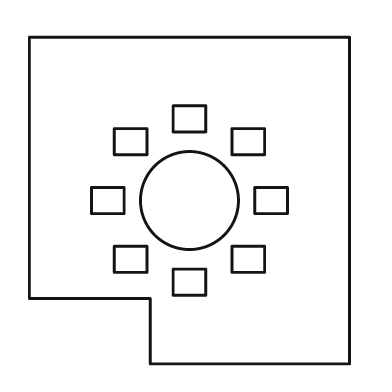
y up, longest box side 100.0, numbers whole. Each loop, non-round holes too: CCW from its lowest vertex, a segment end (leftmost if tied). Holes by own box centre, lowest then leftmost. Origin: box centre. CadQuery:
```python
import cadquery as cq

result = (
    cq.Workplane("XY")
    .moveTo(-12.0, -50.0)
    .lineTo(49.0, -50.0)
    .lineTo(49.0, 50.0)
    .lineTo(-49.0, 50.0)
    .lineTo(-49.0, -30.0)
    .lineTo(-12.0, -30.0)
    .close()
    .moveTo(-5.0, -29.0)
    .lineTo(5.0, -29.0)
    .lineTo(5.0, -21.0)
    .lineTo(-5.0, -21.0)
    .close()
    .moveTo(-23.0, -22.0)
    .lineTo(-13.0, -22.0)
    .lineTo(-13.0, -14.0)
    .lineTo(-23.0, -14.0)
    .close()
    .moveTo(13.0, -22.0)
    .lineTo(23.0, -22.0)
    .lineTo(23.0, -14.0)
    .lineTo(13.0, -14.0)
    .close()
    .moveTo(-30.0, -4.0)
    .lineTo(-20.0, -4.0)
    .lineTo(-20.0, 4.0)
    .lineTo(-30.0, 4.0)
    .close()
    .moveTo(0.0, 0.0)
    .circle(15.0)
    .moveTo(20.0, -4.0)
    .lineTo(30.0, -4.0)
    .lineTo(30.0, 4.0)
    .lineTo(20.0, 4.0)
    .close()
    .moveTo(-23.0, 14.0)
    .lineTo(-13.0, 14.0)
    .lineTo(-13.0, 22.0)
    .lineTo(-23.0, 22.0)
    .close()
    .moveTo(13.0, 14.0)
    .lineTo(23.0, 14.0)
    .lineTo(23.0, 22.0)
    .lineTo(13.0, 22.0)
    .close()
    .moveTo(-5.0, 21.0)
    .lineTo(5.0, 21.0)
    .lineTo(5.0, 29.0)
    .lineTo(-5.0, 29.0)
    .close()
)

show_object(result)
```